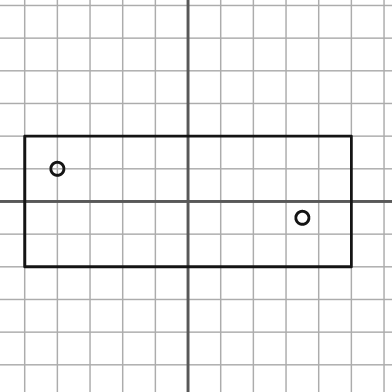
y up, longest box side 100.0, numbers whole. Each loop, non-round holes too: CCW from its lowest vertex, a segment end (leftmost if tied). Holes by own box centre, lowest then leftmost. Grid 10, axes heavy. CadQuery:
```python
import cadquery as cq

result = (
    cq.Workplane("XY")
    .moveTo(-50.0, -20.0)
    .lineTo(50.0, -20.0)
    .lineTo(50.0, 20.0)
    .lineTo(-50.0, 20.0)
    .close()
    .moveTo(35.0, -5.0)
    .circle(2.0)
    .moveTo(-40.0, 10.0)
    .circle(2.0)
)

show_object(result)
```